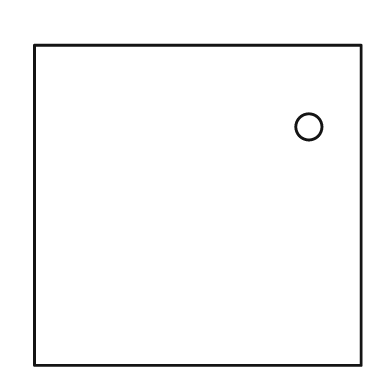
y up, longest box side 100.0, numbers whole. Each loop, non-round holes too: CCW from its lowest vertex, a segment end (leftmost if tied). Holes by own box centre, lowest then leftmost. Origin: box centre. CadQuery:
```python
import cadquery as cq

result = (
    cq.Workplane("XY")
    .moveTo(-50.0, -49.0)
    .lineTo(50.0, -49.0)
    .lineTo(50.0, 49.0)
    .lineTo(-50.0, 49.0)
    .close()
    .moveTo(34.0, 24.0)
    .circle(4.0)
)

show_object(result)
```